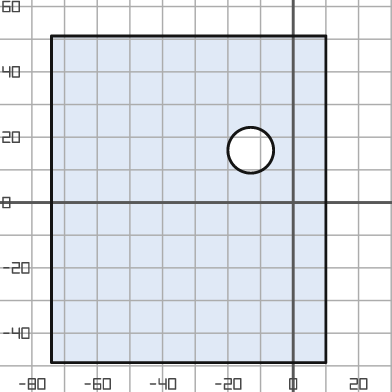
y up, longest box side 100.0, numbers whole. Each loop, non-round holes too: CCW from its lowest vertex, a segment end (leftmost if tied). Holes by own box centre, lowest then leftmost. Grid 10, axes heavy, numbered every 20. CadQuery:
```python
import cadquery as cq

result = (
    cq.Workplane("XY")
    .moveTo(-74.0, -49.0)
    .lineTo(10.0, -49.0)
    .lineTo(10.0, 51.0)
    .lineTo(-74.0, 51.0)
    .close()
    .moveTo(-13.0, 16.0)
    .circle(7.0)
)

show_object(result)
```